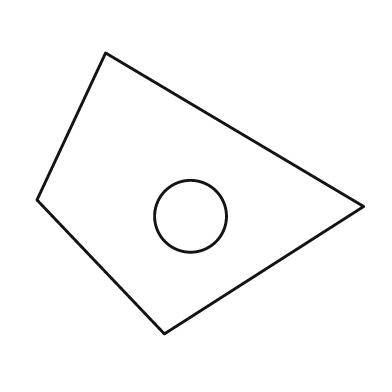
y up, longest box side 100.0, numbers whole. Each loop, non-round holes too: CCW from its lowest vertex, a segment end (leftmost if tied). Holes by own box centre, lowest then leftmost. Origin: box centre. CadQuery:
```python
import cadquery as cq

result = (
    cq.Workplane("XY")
    .moveTo(-11.0, -43.0)
    .lineTo(50.0, -4.0)
    .lineTo(-29.0, 43.0)
    .lineTo(-50.0, -2.0)
    .close()
    .moveTo(-3.0, -7.0)
    .circle(11.0)
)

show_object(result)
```